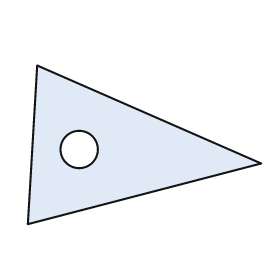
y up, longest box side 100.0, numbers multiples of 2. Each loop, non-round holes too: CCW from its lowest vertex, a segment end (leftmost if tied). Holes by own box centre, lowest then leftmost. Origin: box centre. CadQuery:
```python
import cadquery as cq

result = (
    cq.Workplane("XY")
    .moveTo(-50.0, -34.0)
    .lineTo(50.0, -8.0)
    .lineTo(-46.0, 34.0)
    .close()
    .moveTo(-28.0, -2.0)
    .circle(8.0)
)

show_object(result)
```